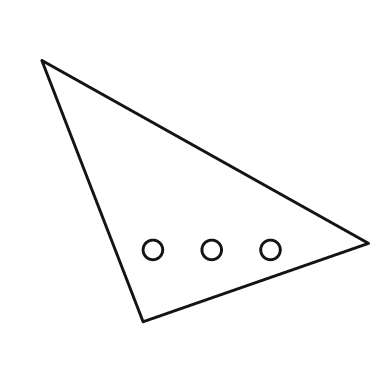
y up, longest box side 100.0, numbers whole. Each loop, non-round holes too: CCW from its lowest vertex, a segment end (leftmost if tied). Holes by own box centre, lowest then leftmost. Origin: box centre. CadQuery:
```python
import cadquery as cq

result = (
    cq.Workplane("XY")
    .moveTo(-19.0, -40.0)
    .lineTo(50.0, -16.0)
    .lineTo(-50.0, 40.0)
    .close()
    .moveTo(-16.0, -18.0)
    .circle(3.0)
    .moveTo(2.0, -18.0)
    .circle(3.0)
    .moveTo(20.0, -18.0)
    .circle(3.0)
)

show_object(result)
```